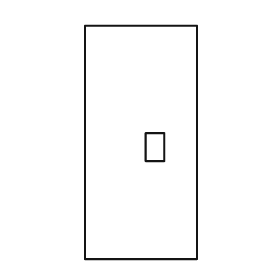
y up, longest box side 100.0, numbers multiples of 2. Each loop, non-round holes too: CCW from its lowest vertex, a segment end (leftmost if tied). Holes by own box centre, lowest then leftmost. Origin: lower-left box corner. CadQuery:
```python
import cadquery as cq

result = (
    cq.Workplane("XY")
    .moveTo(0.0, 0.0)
    .lineTo(48.0, 0.0)
    .lineTo(48.0, 100.0)
    .lineTo(0.0, 100.0)
    .close()
    .moveTo(26.0, 42.0)
    .lineTo(34.0, 42.0)
    .lineTo(34.0, 54.0)
    .lineTo(26.0, 54.0)
    .close()
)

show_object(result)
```